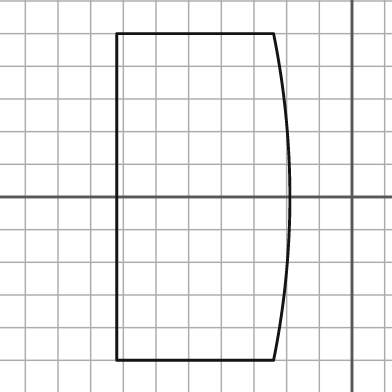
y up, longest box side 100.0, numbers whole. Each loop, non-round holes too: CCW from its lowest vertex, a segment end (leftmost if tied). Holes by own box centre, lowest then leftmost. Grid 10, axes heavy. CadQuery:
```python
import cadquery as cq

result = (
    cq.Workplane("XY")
    .moveTo(-72.0, -50.0)
    .lineTo(-24.0, -50.0)
    .threePointArc((-19.0, 0.0), (-24.0, 50.0))
    .lineTo(-72.0, 50.0)
    .close()
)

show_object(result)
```